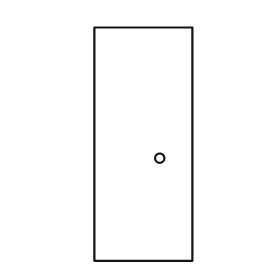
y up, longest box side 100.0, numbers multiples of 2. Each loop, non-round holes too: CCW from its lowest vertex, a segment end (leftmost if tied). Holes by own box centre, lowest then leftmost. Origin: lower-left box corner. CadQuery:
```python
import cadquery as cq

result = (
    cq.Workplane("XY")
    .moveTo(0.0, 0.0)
    .lineTo(42.0, 0.0)
    .lineTo(42.0, 100.0)
    .lineTo(0.0, 100.0)
    .close()
    .moveTo(28.0, 44.0)
    .circle(2.0)
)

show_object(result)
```